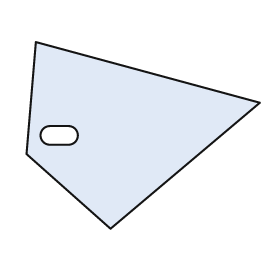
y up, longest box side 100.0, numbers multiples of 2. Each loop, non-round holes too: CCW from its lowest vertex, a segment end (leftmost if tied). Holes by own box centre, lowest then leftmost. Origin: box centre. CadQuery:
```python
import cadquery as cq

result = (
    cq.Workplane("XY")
    .moveTo(-14.0, -40.0)
    .lineTo(50.0, 14.0)
    .lineTo(-46.0, 40.0)
    .lineTo(-50.0, -8.0)
    .close()
    .moveTo(-40.0, -4.0)
    .lineTo(-32.0, -4.0)
    .threePointArc((-28.0, 0.0), (-32.0, 4.0))
    .lineTo(-40.0, 4.0)
    .threePointArc((-44.0, 0.0), (-40.0, -4.0))
    .close()
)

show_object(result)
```